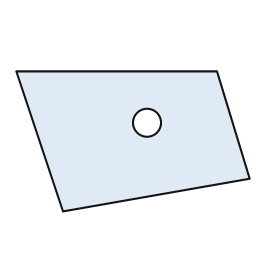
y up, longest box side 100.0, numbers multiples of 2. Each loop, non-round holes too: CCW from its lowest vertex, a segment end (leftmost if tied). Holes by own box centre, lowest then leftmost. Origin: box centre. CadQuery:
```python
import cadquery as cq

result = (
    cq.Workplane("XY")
    .moveTo(-30.0, -30.0)
    .lineTo(50.0, -16.0)
    .lineTo(36.0, 30.0)
    .lineTo(-50.0, 30.0)
    .close()
    .moveTo(6.0, 8.0)
    .circle(6.0)
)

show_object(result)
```